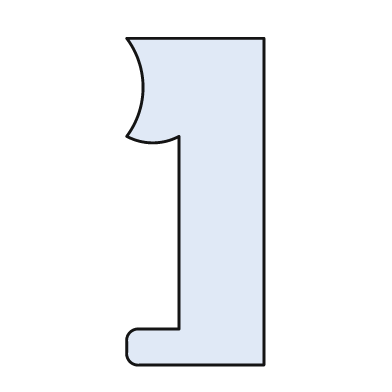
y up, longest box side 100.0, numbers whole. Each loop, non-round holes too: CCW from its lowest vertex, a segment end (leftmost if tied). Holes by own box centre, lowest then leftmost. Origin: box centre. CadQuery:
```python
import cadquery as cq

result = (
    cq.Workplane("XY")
    .moveTo(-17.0, -50.0)
    .lineTo(21.0, -50.0)
    .lineTo(21.0, 50.0)
    .lineTo(-21.0, 50.0)
    .threePointArc((-16.0, 35.0), (-21.0, 20.0))
    .threePointArc((-13.0, 18.0), (-5.0, 20.0))
    .lineTo(-5.0, -39.0)
    .lineTo(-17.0, -39.0)
    .threePointArc((-20.0, -40.0), (-21.0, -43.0))
    .lineTo(-21.0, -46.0)
    .threePointArc((-20.0, -49.0), (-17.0, -50.0))
    .close()
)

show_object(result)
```